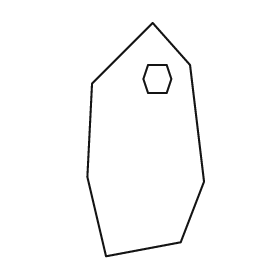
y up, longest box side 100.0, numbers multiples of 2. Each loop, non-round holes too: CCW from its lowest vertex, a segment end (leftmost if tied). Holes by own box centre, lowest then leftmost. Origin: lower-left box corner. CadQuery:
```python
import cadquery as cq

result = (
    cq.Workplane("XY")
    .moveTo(8.0, 0.0)
    .lineTo(40.0, 6.0)
    .lineTo(50.0, 32.0)
    .lineTo(44.0, 82.0)
    .lineTo(28.0, 100.0)
    .lineTo(2.0, 74.0)
    .lineTo(0.0, 34.0)
    .close()
    .moveTo(26.0, 70.0)
    .lineTo(34.0, 70.0)
    .lineTo(36.0, 76.0)
    .lineTo(34.0, 82.0)
    .lineTo(26.0, 82.0)
    .lineTo(24.0, 76.0)
    .close()
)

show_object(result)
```